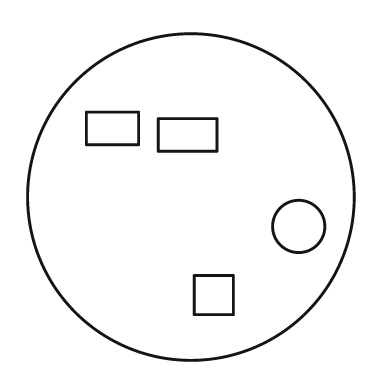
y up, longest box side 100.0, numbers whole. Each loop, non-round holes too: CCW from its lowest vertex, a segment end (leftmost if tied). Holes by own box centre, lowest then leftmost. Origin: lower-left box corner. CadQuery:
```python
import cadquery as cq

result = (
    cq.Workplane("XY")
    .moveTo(50.0, 50.0)
    .circle(50.0)
    .moveTo(51.0, 14.0)
    .lineTo(63.0, 14.0)
    .lineTo(63.0, 26.0)
    .lineTo(51.0, 26.0)
    .close()
    .moveTo(83.0, 41.0)
    .circle(8.0)
    .moveTo(40.0, 64.0)
    .lineTo(58.0, 64.0)
    .lineTo(58.0, 74.0)
    .lineTo(40.0, 74.0)
    .close()
    .moveTo(18.0, 66.0)
    .lineTo(34.0, 66.0)
    .lineTo(34.0, 76.0)
    .lineTo(18.0, 76.0)
    .close()
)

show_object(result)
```